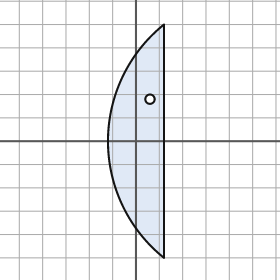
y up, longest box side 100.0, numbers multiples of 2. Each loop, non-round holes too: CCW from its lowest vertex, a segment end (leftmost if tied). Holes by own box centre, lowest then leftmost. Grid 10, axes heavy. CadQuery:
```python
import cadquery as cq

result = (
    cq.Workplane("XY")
    .moveTo(12.0, -50.0)
    .lineTo(12.0, 50.0)
    .threePointArc((-12.0, 0.0), (12.0, -50.0))
    .close()
    .moveTo(6.0, 18.0)
    .circle(2.0)
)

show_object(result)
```